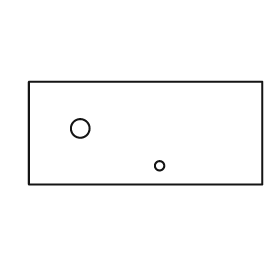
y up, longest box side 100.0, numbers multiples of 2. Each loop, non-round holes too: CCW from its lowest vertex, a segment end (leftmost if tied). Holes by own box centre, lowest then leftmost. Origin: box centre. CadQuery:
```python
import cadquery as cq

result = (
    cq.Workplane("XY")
    .moveTo(-50.0, -22.0)
    .lineTo(50.0, -22.0)
    .lineTo(50.0, 22.0)
    .lineTo(-50.0, 22.0)
    .close()
    .moveTo(6.0, -14.0)
    .circle(2.0)
    .moveTo(-28.0, 2.0)
    .circle(4.0)
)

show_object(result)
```